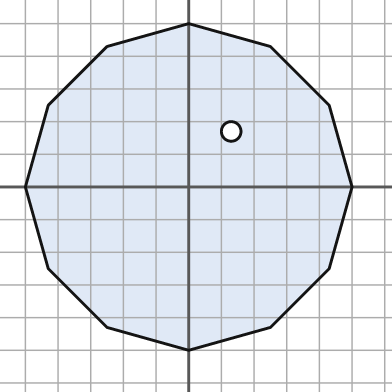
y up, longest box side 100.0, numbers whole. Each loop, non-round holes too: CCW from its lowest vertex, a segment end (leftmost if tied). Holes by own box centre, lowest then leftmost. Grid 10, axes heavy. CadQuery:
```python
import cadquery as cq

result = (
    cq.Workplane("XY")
    .moveTo(0.0, -50.0)
    .lineTo(25.0, -43.0)
    .lineTo(43.0, -25.0)
    .lineTo(50.0, 0.0)
    .lineTo(43.0, 25.0)
    .lineTo(25.0, 43.0)
    .lineTo(0.0, 50.0)
    .lineTo(-25.0, 43.0)
    .lineTo(-43.0, 25.0)
    .lineTo(-50.0, 0.0)
    .lineTo(-43.0, -25.0)
    .lineTo(-25.0, -43.0)
    .close()
    .moveTo(13.0, 17.0)
    .circle(3.0)
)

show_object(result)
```